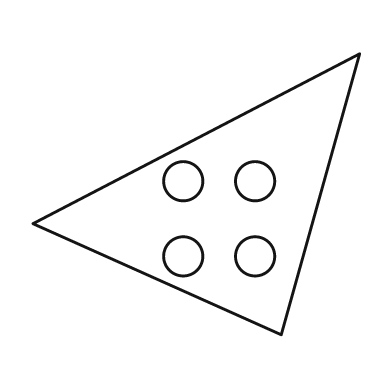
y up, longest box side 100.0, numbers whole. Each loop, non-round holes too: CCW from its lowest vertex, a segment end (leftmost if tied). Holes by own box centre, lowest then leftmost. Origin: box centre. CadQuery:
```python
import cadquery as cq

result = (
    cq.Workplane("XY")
    .moveTo(26.0, -43.0)
    .lineTo(50.0, 43.0)
    .lineTo(-50.0, -9.0)
    .close()
    .moveTo(-4.0, -19.0)
    .circle(6.0)
    .moveTo(18.0, -19.0)
    .circle(6.0)
    .moveTo(-4.0, 4.0)
    .circle(6.0)
    .moveTo(18.0, 4.0)
    .circle(6.0)
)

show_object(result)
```